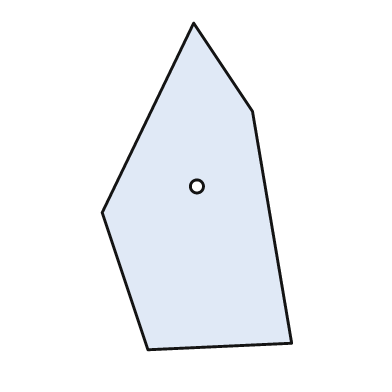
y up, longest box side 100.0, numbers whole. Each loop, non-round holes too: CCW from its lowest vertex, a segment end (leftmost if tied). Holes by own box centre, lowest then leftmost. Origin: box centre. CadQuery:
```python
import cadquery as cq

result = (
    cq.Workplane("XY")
    .moveTo(-15.0, -50.0)
    .lineTo(29.0, -48.0)
    .lineTo(17.0, 23.0)
    .lineTo(-1.0, 50.0)
    .lineTo(-29.0, -8.0)
    .close()
    .moveTo(0.0, 0.0)
    .circle(2.0)
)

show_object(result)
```